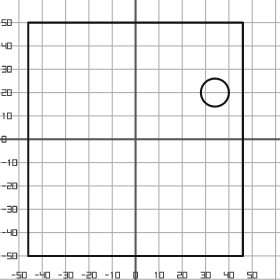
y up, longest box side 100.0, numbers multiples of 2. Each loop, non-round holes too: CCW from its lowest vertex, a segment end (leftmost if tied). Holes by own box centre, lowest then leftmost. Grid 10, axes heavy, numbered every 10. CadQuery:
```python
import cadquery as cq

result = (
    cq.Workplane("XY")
    .moveTo(-46.0, -50.0)
    .lineTo(46.0, -50.0)
    .lineTo(46.0, 50.0)
    .lineTo(-46.0, 50.0)
    .close()
    .moveTo(34.0, 20.0)
    .circle(6.0)
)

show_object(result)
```